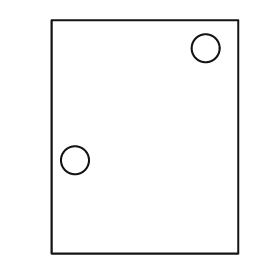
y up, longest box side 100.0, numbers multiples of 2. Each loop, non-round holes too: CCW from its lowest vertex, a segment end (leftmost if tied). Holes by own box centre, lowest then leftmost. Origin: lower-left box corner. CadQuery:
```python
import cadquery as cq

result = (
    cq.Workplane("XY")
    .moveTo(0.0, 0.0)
    .lineTo(80.0, 0.0)
    .lineTo(80.0, 100.0)
    .lineTo(0.0, 100.0)
    .close()
    .moveTo(10.0, 40.0)
    .circle(6.0)
    .moveTo(66.0, 88.0)
    .circle(6.0)
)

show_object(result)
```